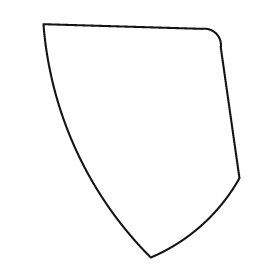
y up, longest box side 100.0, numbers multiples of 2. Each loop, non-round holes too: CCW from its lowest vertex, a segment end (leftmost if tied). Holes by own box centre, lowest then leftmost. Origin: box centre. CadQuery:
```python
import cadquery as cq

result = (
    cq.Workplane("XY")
    .moveTo(4.0, -50.0)
    .threePointArc((26.0, -36.0), (42.0, -16.0))
    .lineTo(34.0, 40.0)
    .threePointArc((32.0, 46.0), (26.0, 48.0))
    .lineTo(-42.0, 50.0)
    .threePointArc((-28.0, -4.0), (4.0, -50.0))
    .close()
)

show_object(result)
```